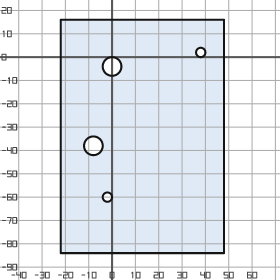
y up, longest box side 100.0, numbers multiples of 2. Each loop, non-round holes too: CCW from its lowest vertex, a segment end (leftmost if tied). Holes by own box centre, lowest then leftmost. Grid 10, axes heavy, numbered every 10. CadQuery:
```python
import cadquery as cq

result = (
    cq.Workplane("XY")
    .moveTo(-22.0, -84.0)
    .lineTo(48.0, -84.0)
    .lineTo(48.0, 16.0)
    .lineTo(-22.0, 16.0)
    .close()
    .moveTo(-2.0, -60.0)
    .circle(2.0)
    .moveTo(-8.0, -38.0)
    .circle(4.0)
    .moveTo(0.0, -4.0)
    .circle(4.0)
    .moveTo(38.0, 2.0)
    .circle(2.0)
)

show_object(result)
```